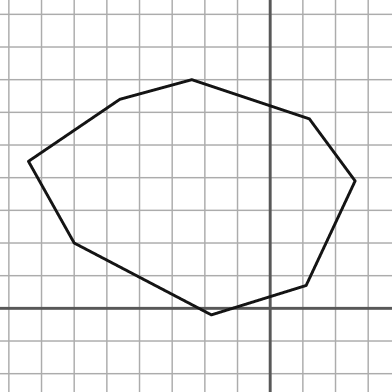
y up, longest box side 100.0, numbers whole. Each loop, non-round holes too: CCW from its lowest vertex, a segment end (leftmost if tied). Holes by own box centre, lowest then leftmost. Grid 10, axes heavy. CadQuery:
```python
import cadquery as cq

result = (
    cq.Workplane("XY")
    .moveTo(-18.0, -2.0)
    .lineTo(11.0, 7.0)
    .lineTo(26.0, 39.0)
    .lineTo(12.0, 58.0)
    .lineTo(-24.0, 70.0)
    .lineTo(-46.0, 64.0)
    .lineTo(-74.0, 45.0)
    .lineTo(-60.0, 20.0)
    .close()
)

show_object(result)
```